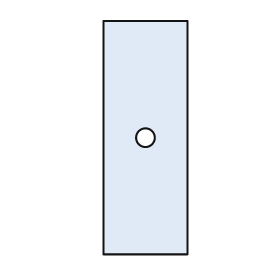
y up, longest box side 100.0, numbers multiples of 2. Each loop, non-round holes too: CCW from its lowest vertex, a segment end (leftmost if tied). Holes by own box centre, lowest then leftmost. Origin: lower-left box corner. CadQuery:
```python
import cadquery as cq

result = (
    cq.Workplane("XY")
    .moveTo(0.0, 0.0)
    .lineTo(36.0, 0.0)
    .lineTo(36.0, 100.0)
    .lineTo(0.0, 100.0)
    .close()
    .moveTo(18.0, 50.0)
    .circle(4.0)
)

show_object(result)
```